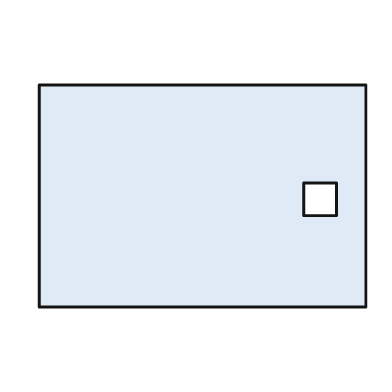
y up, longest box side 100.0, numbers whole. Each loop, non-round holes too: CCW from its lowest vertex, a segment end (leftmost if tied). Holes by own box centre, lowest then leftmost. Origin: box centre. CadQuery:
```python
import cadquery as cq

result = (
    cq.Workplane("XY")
    .moveTo(-50.0, -34.0)
    .lineTo(50.0, -34.0)
    .lineTo(50.0, 34.0)
    .lineTo(-50.0, 34.0)
    .close()
    .moveTo(31.0, -6.0)
    .lineTo(41.0, -6.0)
    .lineTo(41.0, 4.0)
    .lineTo(31.0, 4.0)
    .close()
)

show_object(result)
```